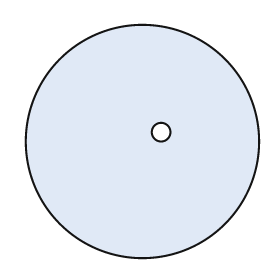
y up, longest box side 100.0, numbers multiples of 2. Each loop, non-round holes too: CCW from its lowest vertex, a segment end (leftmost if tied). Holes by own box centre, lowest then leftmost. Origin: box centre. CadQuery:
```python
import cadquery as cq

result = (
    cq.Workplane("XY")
    .moveTo(0.0, 0.0)
    .circle(50.0)
    .moveTo(8.0, 4.0)
    .circle(4.0)
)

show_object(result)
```